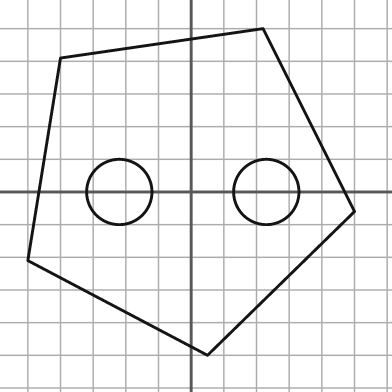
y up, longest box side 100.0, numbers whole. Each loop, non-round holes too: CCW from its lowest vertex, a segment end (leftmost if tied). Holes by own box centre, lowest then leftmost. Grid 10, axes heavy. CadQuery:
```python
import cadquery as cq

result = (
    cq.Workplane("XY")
    .moveTo(5.0, -50.0)
    .lineTo(50.0, -6.0)
    .lineTo(22.0, 50.0)
    .lineTo(-40.0, 41.0)
    .lineTo(-50.0, -21.0)
    .close()
    .moveTo(-22.0, 0.0)
    .circle(10.0)
    .moveTo(23.0, 0.0)
    .circle(10.0)
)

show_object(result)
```